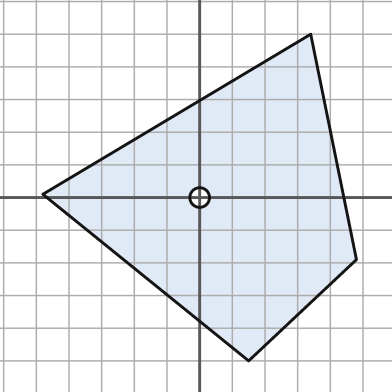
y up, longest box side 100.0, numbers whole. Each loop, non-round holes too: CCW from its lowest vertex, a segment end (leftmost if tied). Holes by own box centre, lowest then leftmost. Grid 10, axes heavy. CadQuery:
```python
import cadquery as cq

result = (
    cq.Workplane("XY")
    .moveTo(15.0, -50.0)
    .lineTo(48.0, -19.0)
    .lineTo(34.0, 50.0)
    .lineTo(-48.0, 1.0)
    .close()
    .moveTo(0.0, 0.0)
    .circle(3.0)
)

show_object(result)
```